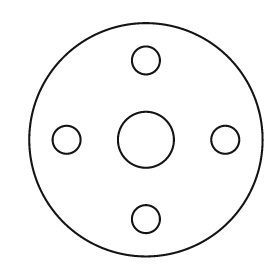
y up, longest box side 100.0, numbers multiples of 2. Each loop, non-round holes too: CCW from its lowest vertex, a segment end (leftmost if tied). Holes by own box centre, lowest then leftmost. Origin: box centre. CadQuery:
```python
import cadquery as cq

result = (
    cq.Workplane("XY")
    .moveTo(0.0, 0.0)
    .circle(50.0)
    .moveTo(0.0, -34.0)
    .circle(6.0)
    .moveTo(-34.0, 0.0)
    .circle(6.0)
    .moveTo(0.0, 0.0)
    .circle(12.0)
    .moveTo(34.0, 0.0)
    .circle(6.0)
    .moveTo(0.0, 34.0)
    .circle(6.0)
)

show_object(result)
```